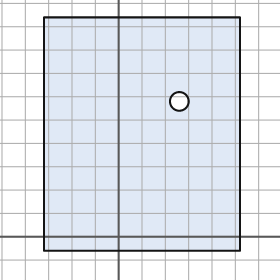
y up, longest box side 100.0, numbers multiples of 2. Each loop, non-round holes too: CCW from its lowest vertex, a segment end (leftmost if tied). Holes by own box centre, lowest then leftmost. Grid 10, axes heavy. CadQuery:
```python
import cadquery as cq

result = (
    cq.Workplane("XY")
    .moveTo(-32.0, -6.0)
    .lineTo(52.0, -6.0)
    .lineTo(52.0, 94.0)
    .lineTo(-32.0, 94.0)
    .close()
    .moveTo(26.0, 58.0)
    .circle(4.0)
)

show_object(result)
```